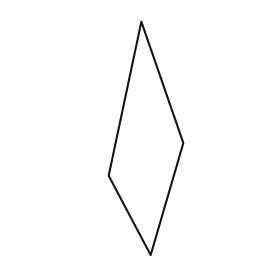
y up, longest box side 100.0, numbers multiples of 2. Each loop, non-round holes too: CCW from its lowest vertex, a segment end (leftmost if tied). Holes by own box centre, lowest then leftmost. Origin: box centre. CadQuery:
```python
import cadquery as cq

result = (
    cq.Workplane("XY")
    .moveTo(2.0, -50.0)
    .lineTo(16.0, -2.0)
    .lineTo(-2.0, 50.0)
    .lineTo(-16.0, -16.0)
    .close()
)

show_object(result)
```